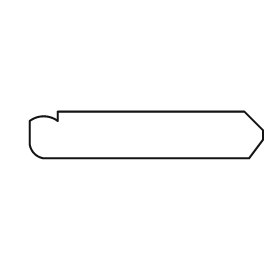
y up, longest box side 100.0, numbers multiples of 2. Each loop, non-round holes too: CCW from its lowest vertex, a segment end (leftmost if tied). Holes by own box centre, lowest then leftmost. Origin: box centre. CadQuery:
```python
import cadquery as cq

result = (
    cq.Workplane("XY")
    .moveTo(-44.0, -10.0)
    .lineTo(44.0, -10.0)
    .lineTo(50.0, -2.0)
    .lineTo(50.0, 2.0)
    .lineTo(42.0, 10.0)
    .lineTo(-38.0, 10.0)
    .lineTo(-38.0, 6.0)
    .threePointArc((-44.0, 8.0), (-50.0, 6.0))
    .lineTo(-50.0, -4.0)
    .threePointArc((-48.0, -8.0), (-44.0, -10.0))
    .close()
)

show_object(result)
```